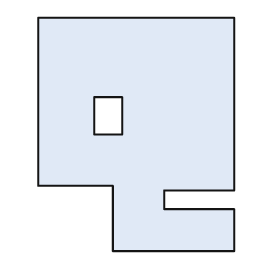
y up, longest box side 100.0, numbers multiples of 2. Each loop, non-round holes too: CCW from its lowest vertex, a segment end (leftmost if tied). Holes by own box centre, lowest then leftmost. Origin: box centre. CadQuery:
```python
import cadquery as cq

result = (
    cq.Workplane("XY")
    .moveTo(-10.0, -50.0)
    .lineTo(42.0, -50.0)
    .lineTo(42.0, -32.0)
    .lineTo(12.0, -32.0)
    .lineTo(12.0, -24.0)
    .lineTo(42.0, -24.0)
    .lineTo(42.0, 50.0)
    .lineTo(-42.0, 50.0)
    .lineTo(-42.0, -22.0)
    .lineTo(-10.0, -22.0)
    .close()
    .moveTo(-18.0, 0.0)
    .lineTo(-6.0, 0.0)
    .lineTo(-6.0, 16.0)
    .lineTo(-18.0, 16.0)
    .close()
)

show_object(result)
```